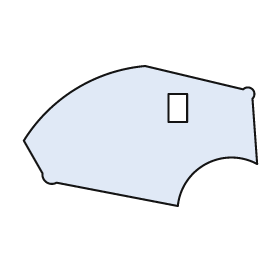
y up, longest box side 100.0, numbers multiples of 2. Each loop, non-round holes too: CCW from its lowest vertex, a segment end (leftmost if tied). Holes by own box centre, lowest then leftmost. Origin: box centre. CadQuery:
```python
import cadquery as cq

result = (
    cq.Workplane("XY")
    .moveTo(16.0, -30.0)
    .threePointArc((28.0, -12.0), (50.0, -12.0))
    .lineTo(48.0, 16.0)
    .threePointArc((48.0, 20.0), (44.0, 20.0))
    .lineTo(2.0, 30.0)
    .threePointArc((-28.0, 20.0), (-50.0, -2.0))
    .lineTo(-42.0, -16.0)
    .threePointArc((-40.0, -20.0), (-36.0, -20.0))
    .close()
    .moveTo(12.0, 6.0)
    .lineTo(20.0, 6.0)
    .lineTo(20.0, 18.0)
    .lineTo(12.0, 18.0)
    .close()
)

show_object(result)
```